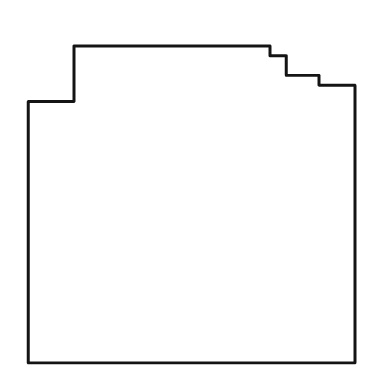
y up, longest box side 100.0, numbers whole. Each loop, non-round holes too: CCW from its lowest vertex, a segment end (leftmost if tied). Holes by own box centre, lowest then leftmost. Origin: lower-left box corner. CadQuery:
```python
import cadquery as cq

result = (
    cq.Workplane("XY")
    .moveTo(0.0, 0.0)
    .lineTo(100.0, 0.0)
    .lineTo(100.0, 85.0)
    .lineTo(89.0, 85.0)
    .lineTo(89.0, 88.0)
    .lineTo(79.0, 88.0)
    .lineTo(79.0, 94.0)
    .lineTo(74.0, 94.0)
    .lineTo(74.0, 97.0)
    .lineTo(14.0, 97.0)
    .lineTo(14.0, 80.0)
    .lineTo(0.0, 80.0)
    .close()
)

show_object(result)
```